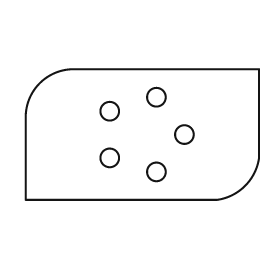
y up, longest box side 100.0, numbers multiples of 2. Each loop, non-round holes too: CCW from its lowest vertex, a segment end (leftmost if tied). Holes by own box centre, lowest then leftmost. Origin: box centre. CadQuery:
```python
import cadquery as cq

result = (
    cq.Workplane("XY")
    .moveTo(-50.0, -28.0)
    .lineTo(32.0, -28.0)
    .threePointArc((44.0, -22.0), (50.0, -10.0))
    .lineTo(50.0, 28.0)
    .lineTo(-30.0, 28.0)
    .threePointArc((-44.0, 22.0), (-50.0, 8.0))
    .close()
    .moveTo(6.0, -16.0)
    .circle(4.0)
    .moveTo(-14.0, -10.0)
    .circle(4.0)
    .moveTo(18.0, 0.0)
    .circle(4.0)
    .moveTo(-14.0, 10.0)
    .circle(4.0)
    .moveTo(6.0, 16.0)
    .circle(4.0)
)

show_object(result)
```